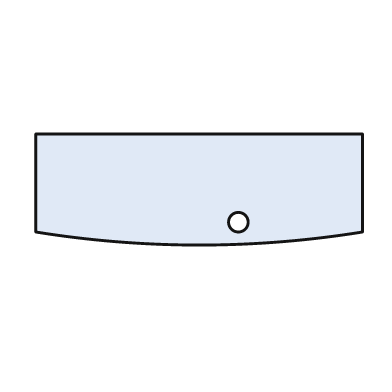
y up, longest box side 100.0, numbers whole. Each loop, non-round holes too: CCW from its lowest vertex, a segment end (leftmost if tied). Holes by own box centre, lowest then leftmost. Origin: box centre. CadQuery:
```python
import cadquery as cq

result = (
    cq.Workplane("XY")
    .moveTo(-50.0, -13.0)
    .threePointArc((0.0, -17.0), (50.0, -13.0))
    .lineTo(50.0, 17.0)
    .lineTo(-50.0, 17.0)
    .close()
    .moveTo(12.0, -10.0)
    .circle(3.0)
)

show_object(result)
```